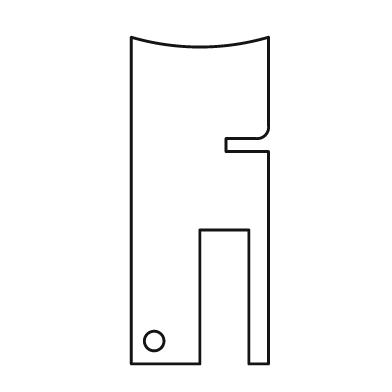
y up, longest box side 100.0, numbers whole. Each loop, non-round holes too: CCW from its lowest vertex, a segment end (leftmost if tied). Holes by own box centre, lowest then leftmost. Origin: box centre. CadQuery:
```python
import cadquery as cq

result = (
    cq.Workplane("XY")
    .moveTo(-21.0, -50.0)
    .lineTo(0.0, -50.0)
    .lineTo(0.0, -9.0)
    .lineTo(15.0, -9.0)
    .lineTo(15.0, -50.0)
    .lineTo(21.0, -50.0)
    .lineTo(21.0, 15.0)
    .lineTo(8.0, 15.0)
    .lineTo(8.0, 19.0)
    .lineTo(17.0, 19.0)
    .threePointArc((20.0, 20.0), (21.0, 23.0))
    .lineTo(21.0, 50.0)
    .threePointArc((0.0, 47.0), (-21.0, 50.0))
    .close()
    .moveTo(-14.0, -43.0)
    .circle(3.0)
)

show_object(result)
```